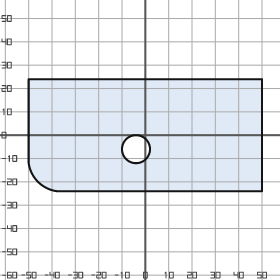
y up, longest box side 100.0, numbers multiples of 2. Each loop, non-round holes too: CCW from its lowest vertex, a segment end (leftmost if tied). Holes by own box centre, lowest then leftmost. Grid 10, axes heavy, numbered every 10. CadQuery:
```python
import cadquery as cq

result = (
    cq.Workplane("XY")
    .moveTo(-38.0, -24.0)
    .lineTo(50.0, -24.0)
    .lineTo(50.0, 24.0)
    .lineTo(-50.0, 24.0)
    .lineTo(-50.0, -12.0)
    .threePointArc((-46.0, -20.0), (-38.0, -24.0))
    .close()
    .moveTo(-4.0, -6.0)
    .circle(6.0)
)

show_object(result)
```